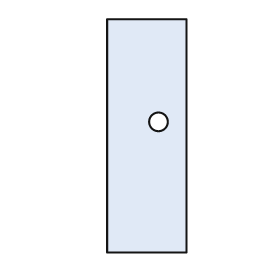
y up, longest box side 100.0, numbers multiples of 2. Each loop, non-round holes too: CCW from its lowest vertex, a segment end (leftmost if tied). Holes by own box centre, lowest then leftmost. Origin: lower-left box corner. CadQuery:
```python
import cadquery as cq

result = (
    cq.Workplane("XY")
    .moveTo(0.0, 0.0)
    .lineTo(34.0, 0.0)
    .lineTo(34.0, 100.0)
    .lineTo(0.0, 100.0)
    .close()
    .moveTo(22.0, 56.0)
    .circle(4.0)
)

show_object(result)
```